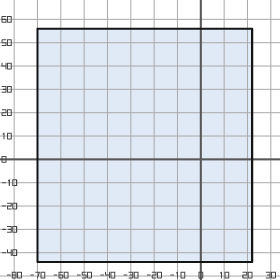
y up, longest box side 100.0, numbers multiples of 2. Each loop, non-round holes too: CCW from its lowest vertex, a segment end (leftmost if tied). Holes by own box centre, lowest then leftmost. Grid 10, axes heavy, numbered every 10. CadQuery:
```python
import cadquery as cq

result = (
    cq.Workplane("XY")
    .moveTo(-70.0, -44.0)
    .lineTo(22.0, -44.0)
    .lineTo(22.0, 56.0)
    .lineTo(-70.0, 56.0)
    .close()
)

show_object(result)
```